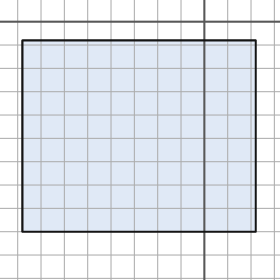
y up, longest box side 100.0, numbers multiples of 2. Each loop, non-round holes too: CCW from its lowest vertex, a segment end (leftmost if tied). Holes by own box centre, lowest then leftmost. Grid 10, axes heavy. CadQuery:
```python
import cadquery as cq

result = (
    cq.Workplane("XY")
    .moveTo(-78.0, -90.0)
    .lineTo(22.0, -90.0)
    .lineTo(22.0, -8.0)
    .lineTo(-78.0, -8.0)
    .close()
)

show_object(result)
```